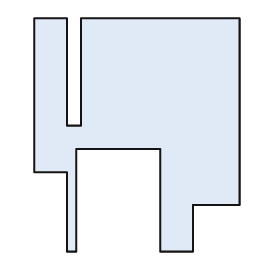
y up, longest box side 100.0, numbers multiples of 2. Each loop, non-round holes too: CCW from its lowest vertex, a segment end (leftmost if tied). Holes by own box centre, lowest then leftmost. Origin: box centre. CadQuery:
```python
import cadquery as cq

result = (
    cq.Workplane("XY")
    .moveTo(-30.0, -50.0)
    .lineTo(-26.0, -50.0)
    .lineTo(-26.0, -6.0)
    .lineTo(10.0, -6.0)
    .lineTo(10.0, -50.0)
    .lineTo(24.0, -50.0)
    .lineTo(24.0, -30.0)
    .lineTo(44.0, -30.0)
    .lineTo(44.0, 50.0)
    .lineTo(-24.0, 50.0)
    .lineTo(-24.0, 4.0)
    .lineTo(-30.0, 4.0)
    .lineTo(-30.0, 50.0)
    .lineTo(-44.0, 50.0)
    .lineTo(-44.0, -16.0)
    .lineTo(-30.0, -16.0)
    .close()
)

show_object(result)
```